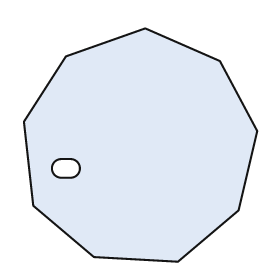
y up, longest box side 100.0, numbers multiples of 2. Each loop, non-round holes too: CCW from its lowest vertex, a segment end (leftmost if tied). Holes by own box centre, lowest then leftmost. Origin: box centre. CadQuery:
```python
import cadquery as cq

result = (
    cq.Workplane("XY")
    .moveTo(16.0, -50.0)
    .lineTo(42.0, -28.0)
    .lineTo(50.0, 6.0)
    .lineTo(34.0, 36.0)
    .lineTo(2.0, 50.0)
    .lineTo(-32.0, 38.0)
    .lineTo(-50.0, 10.0)
    .lineTo(-46.0, -26.0)
    .lineTo(-20.0, -48.0)
    .close()
    .moveTo(-34.0, -14.0)
    .lineTo(-30.0, -14.0)
    .threePointArc((-26.0, -10.0), (-30.0, -6.0))
    .lineTo(-34.0, -6.0)
    .threePointArc((-38.0, -10.0), (-34.0, -14.0))
    .close()
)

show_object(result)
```